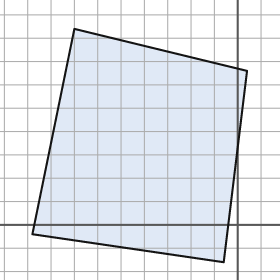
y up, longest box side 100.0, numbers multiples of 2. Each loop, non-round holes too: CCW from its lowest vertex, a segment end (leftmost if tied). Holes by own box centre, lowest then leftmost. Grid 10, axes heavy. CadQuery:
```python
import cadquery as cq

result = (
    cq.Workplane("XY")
    .moveTo(-6.0, -16.0)
    .lineTo(4.0, 66.0)
    .lineTo(-70.0, 84.0)
    .lineTo(-88.0, -4.0)
    .close()
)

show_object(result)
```